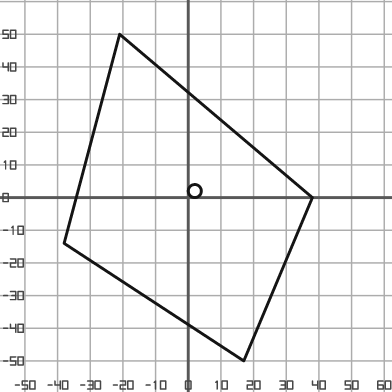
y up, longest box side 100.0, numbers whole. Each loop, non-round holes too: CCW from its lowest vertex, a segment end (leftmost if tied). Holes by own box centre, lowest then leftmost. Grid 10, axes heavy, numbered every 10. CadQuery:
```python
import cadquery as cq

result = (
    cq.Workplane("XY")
    .moveTo(17.0, -50.0)
    .lineTo(38.0, 0.0)
    .lineTo(-21.0, 50.0)
    .lineTo(-38.0, -14.0)
    .close()
    .moveTo(2.0, 2.0)
    .circle(2.0)
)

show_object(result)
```